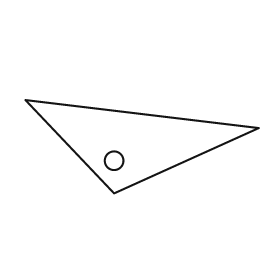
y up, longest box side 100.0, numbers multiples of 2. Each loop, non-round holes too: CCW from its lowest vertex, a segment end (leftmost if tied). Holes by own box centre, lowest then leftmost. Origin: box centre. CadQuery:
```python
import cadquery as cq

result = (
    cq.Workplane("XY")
    .moveTo(-12.0, -20.0)
    .lineTo(50.0, 8.0)
    .lineTo(-50.0, 20.0)
    .close()
    .moveTo(-12.0, -6.0)
    .circle(4.0)
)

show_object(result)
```